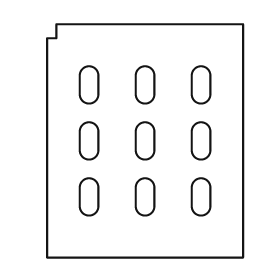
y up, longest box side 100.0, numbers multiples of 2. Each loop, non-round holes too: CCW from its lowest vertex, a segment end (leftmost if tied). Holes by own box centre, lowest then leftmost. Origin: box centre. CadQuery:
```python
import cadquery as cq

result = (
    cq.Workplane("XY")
    .moveTo(-42.0, -50.0)
    .lineTo(42.0, -50.0)
    .lineTo(42.0, 50.0)
    .lineTo(-38.0, 50.0)
    .lineTo(-38.0, 44.0)
    .lineTo(-42.0, 44.0)
    .close()
    .moveTo(-28.0, -28.0)
    .threePointArc((-24.0, -32.0), (-20.0, -28.0))
    .lineTo(-20.0, -20.0)
    .threePointArc((-24.0, -16.0), (-28.0, -20.0))
    .close()
    .moveTo(-4.0, -28.0)
    .threePointArc((0.0, -32.0), (4.0, -28.0))
    .lineTo(4.0, -20.0)
    .threePointArc((0.0, -16.0), (-4.0, -20.0))
    .close()
    .moveTo(20.0, -28.0)
    .threePointArc((24.0, -32.0), (28.0, -28.0))
    .lineTo(28.0, -20.0)
    .threePointArc((24.0, -16.0), (20.0, -20.0))
    .close()
    .moveTo(-28.0, -4.0)
    .threePointArc((-24.0, -8.0), (-20.0, -4.0))
    .lineTo(-20.0, 4.0)
    .threePointArc((-24.0, 8.0), (-28.0, 4.0))
    .close()
    .moveTo(-4.0, -4.0)
    .threePointArc((0.0, -8.0), (4.0, -4.0))
    .lineTo(4.0, 4.0)
    .threePointArc((0.0, 8.0), (-4.0, 4.0))
    .close()
    .moveTo(20.0, -4.0)
    .threePointArc((24.0, -8.0), (28.0, -4.0))
    .lineTo(28.0, 4.0)
    .threePointArc((24.0, 8.0), (20.0, 4.0))
    .close()
    .moveTo(-28.0, 20.0)
    .threePointArc((-24.0, 16.0), (-20.0, 20.0))
    .lineTo(-20.0, 28.0)
    .threePointArc((-24.0, 32.0), (-28.0, 28.0))
    .close()
    .moveTo(-4.0, 20.0)
    .threePointArc((0.0, 16.0), (4.0, 20.0))
    .lineTo(4.0, 28.0)
    .threePointArc((0.0, 32.0), (-4.0, 28.0))
    .close()
    .moveTo(20.0, 20.0)
    .threePointArc((24.0, 16.0), (28.0, 20.0))
    .lineTo(28.0, 28.0)
    .threePointArc((24.0, 32.0), (20.0, 28.0))
    .close()
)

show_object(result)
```